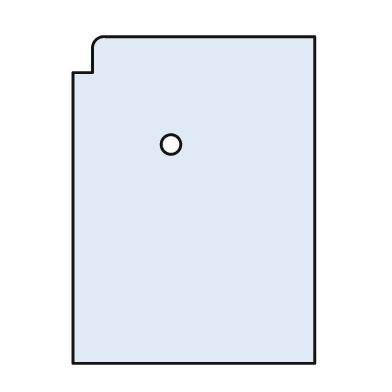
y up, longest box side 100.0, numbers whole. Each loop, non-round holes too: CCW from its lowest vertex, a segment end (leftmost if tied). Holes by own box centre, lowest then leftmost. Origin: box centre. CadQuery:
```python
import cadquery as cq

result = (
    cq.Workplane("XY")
    .moveTo(-37.0, -50.0)
    .lineTo(37.0, -50.0)
    .lineTo(37.0, 50.0)
    .lineTo(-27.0, 50.0)
    .threePointArc((-30.0, 49.0), (-31.0, 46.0))
    .lineTo(-31.0, 39.0)
    .lineTo(-37.0, 39.0)
    .close()
    .moveTo(-7.0, 17.0)
    .circle(3.0)
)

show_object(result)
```